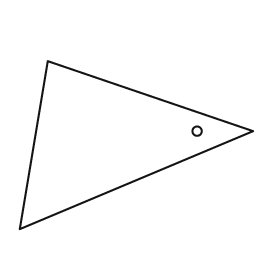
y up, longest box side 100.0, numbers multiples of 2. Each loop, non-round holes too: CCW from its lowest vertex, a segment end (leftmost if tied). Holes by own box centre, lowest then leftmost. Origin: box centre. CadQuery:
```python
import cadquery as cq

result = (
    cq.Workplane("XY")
    .moveTo(-50.0, -36.0)
    .lineTo(50.0, 6.0)
    .lineTo(-38.0, 36.0)
    .close()
    .moveTo(26.0, 6.0)
    .circle(2.0)
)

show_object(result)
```